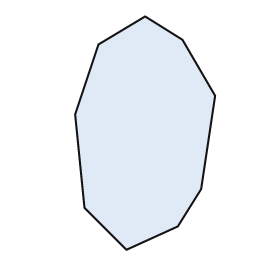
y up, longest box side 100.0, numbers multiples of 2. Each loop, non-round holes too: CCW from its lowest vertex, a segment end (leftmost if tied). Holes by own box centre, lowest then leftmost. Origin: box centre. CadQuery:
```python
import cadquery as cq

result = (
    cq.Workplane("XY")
    .moveTo(-8.0, -50.0)
    .lineTo(14.0, -40.0)
    .lineTo(24.0, -24.0)
    .lineTo(30.0, 16.0)
    .lineTo(16.0, 40.0)
    .lineTo(0.0, 50.0)
    .lineTo(-20.0, 38.0)
    .lineTo(-30.0, 8.0)
    .lineTo(-26.0, -32.0)
    .close()
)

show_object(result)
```